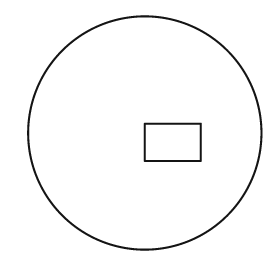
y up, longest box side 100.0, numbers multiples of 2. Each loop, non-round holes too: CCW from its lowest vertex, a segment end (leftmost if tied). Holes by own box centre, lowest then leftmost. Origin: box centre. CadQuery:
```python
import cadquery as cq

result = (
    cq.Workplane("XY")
    .moveTo(0.0, 0.0)
    .circle(50.0)
    .moveTo(0.0, -12.0)
    .lineTo(24.0, -12.0)
    .lineTo(24.0, 4.0)
    .lineTo(0.0, 4.0)
    .close()
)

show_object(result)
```